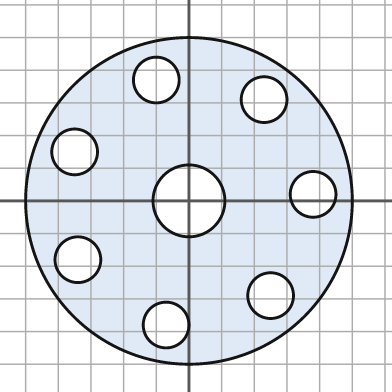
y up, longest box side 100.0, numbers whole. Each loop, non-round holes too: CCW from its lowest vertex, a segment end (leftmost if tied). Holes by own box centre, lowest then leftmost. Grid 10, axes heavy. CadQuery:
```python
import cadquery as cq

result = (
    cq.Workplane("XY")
    .moveTo(0.0, 0.0)
    .circle(50.0)
    .moveTo(-7.0, -38.0)
    .circle(7.0)
    .moveTo(25.0, -29.0)
    .circle(7.0)
    .moveTo(-34.0, -18.0)
    .circle(7.0)
    .moveTo(0.0, 0.0)
    .circle(11.0)
    .moveTo(38.0, 2.0)
    .circle(7.0)
    .moveTo(-35.0, 15.0)
    .circle(7.0)
    .moveTo(23.0, 31.0)
    .circle(7.0)
    .moveTo(-10.0, 37.0)
    .circle(7.0)
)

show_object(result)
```